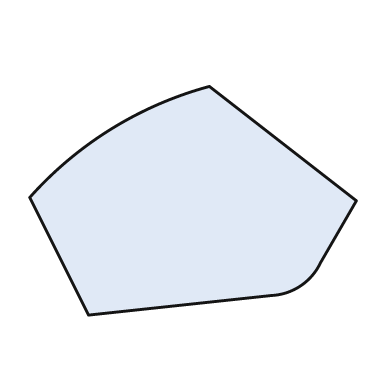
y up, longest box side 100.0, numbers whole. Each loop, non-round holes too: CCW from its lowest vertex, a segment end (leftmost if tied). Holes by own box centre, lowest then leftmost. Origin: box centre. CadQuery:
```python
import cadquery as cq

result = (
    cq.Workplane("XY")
    .moveTo(-32.0, -35.0)
    .lineTo(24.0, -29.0)
    .threePointArc((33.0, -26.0), (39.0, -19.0))
    .lineTo(50.0, 0.0)
    .lineTo(5.0, 35.0)
    .threePointArc((-25.0, 22.0), (-50.0, 1.0))
    .close()
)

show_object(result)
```